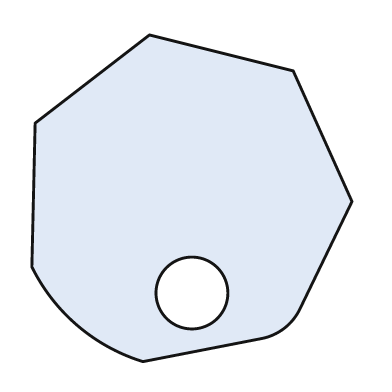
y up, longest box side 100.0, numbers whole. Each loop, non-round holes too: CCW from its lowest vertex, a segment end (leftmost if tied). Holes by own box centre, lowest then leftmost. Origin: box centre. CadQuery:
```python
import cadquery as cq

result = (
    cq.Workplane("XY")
    .moveTo(-15.0, -50.0)
    .lineTo(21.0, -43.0)
    .threePointArc((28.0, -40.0), (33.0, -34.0))
    .lineTo(49.0, -1.0)
    .lineTo(31.0, 39.0)
    .lineTo(-13.0, 50.0)
    .lineTo(-48.0, 23.0)
    .lineTo(-49.0, -21.0)
    .threePointArc((-35.0, -39.0), (-15.0, -50.0))
    .close()
    .moveTo(0.0, -29.0)
    .circle(11.0)
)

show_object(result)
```